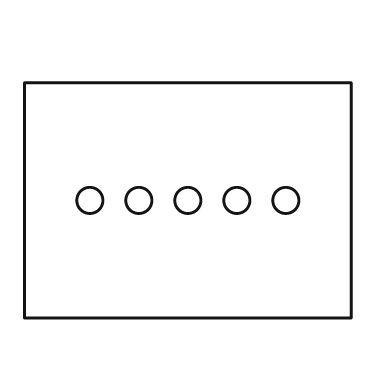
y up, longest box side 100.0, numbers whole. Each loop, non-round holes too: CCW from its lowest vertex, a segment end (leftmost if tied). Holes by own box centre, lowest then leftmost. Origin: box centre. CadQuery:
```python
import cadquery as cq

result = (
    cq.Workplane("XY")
    .moveTo(-50.0, -36.0)
    .lineTo(50.0, -36.0)
    .lineTo(50.0, 36.0)
    .lineTo(-50.0, 36.0)
    .close()
    .moveTo(-30.0, 0.0)
    .circle(4.0)
    .moveTo(-15.0, 0.0)
    .circle(4.0)
    .moveTo(0.0, 0.0)
    .circle(4.0)
    .moveTo(15.0, 0.0)
    .circle(4.0)
    .moveTo(30.0, 0.0)
    .circle(4.0)
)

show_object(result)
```